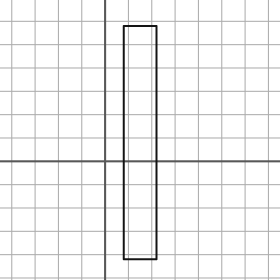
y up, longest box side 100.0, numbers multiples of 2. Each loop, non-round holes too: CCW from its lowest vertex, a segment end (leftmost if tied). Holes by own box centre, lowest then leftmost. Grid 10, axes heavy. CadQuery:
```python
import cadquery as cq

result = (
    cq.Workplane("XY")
    .moveTo(8.0, -42.0)
    .lineTo(22.0, -42.0)
    .lineTo(22.0, 58.0)
    .lineTo(8.0, 58.0)
    .close()
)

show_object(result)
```